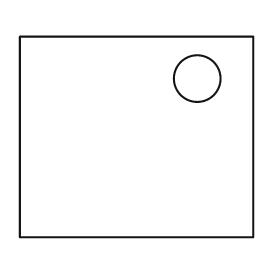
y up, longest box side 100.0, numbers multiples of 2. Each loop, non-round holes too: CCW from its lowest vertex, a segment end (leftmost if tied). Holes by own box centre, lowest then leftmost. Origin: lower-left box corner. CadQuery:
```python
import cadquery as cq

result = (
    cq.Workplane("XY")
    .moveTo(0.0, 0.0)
    .lineTo(100.0, 0.0)
    .lineTo(100.0, 86.0)
    .lineTo(0.0, 86.0)
    .close()
    .moveTo(76.0, 68.0)
    .circle(10.0)
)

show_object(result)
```